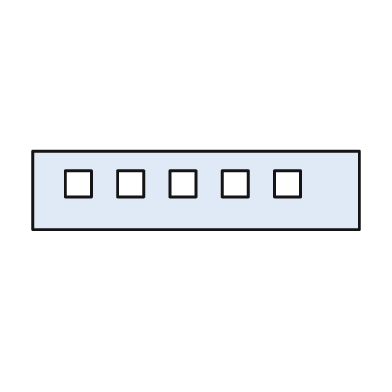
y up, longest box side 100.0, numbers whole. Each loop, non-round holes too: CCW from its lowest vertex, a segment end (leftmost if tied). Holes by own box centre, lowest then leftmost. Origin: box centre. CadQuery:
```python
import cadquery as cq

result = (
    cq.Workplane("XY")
    .moveTo(-50.0, -12.0)
    .lineTo(50.0, -12.0)
    .lineTo(50.0, 12.0)
    .lineTo(-50.0, 12.0)
    .close()
    .moveTo(-40.0, -2.0)
    .lineTo(-32.0, -2.0)
    .lineTo(-32.0, 6.0)
    .lineTo(-40.0, 6.0)
    .close()
    .moveTo(-24.0, -2.0)
    .lineTo(-16.0, -2.0)
    .lineTo(-16.0, 6.0)
    .lineTo(-24.0, 6.0)
    .close()
    .moveTo(-8.0, -2.0)
    .lineTo(0.0, -2.0)
    .lineTo(0.0, 6.0)
    .lineTo(-8.0, 6.0)
    .close()
    .moveTo(8.0, -2.0)
    .lineTo(16.0, -2.0)
    .lineTo(16.0, 6.0)
    .lineTo(8.0, 6.0)
    .close()
    .moveTo(24.0, -2.0)
    .lineTo(32.0, -2.0)
    .lineTo(32.0, 6.0)
    .lineTo(24.0, 6.0)
    .close()
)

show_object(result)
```